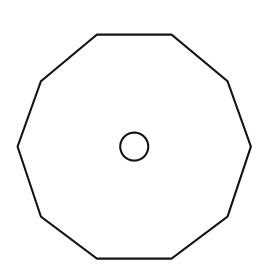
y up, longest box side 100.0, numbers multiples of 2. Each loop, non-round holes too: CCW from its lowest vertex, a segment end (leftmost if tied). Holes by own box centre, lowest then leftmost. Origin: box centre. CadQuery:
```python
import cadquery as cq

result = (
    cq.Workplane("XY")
    .moveTo(-16.0, -48.0)
    .lineTo(16.0, -48.0)
    .lineTo(40.0, -30.0)
    .lineTo(50.0, 0.0)
    .lineTo(40.0, 28.0)
    .lineTo(16.0, 48.0)
    .lineTo(-16.0, 48.0)
    .lineTo(-40.0, 28.0)
    .lineTo(-50.0, 0.0)
    .lineTo(-40.0, -30.0)
    .close()
    .moveTo(0.0, 0.0)
    .circle(6.0)
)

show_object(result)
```